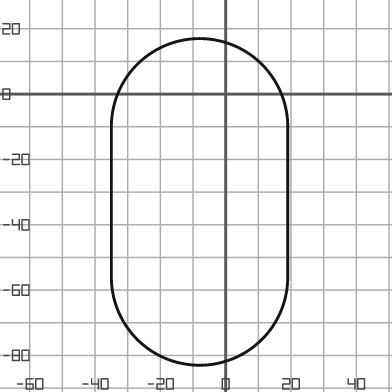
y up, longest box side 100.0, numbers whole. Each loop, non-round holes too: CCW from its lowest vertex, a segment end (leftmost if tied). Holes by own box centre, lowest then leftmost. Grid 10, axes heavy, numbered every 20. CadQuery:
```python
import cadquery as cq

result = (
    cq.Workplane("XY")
    .moveTo(-35.0, -56.0)
    .threePointArc((-8.0, -83.0), (19.0, -56.0))
    .lineTo(19.0, -10.0)
    .threePointArc((-8.0, 17.0), (-35.0, -10.0))
    .close()
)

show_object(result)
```